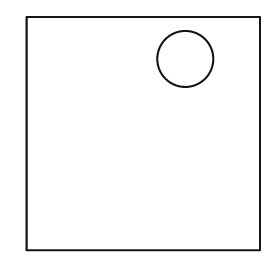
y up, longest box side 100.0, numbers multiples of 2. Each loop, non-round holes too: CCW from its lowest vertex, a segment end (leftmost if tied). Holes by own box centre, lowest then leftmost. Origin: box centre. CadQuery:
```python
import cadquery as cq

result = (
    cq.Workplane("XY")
    .moveTo(-50.0, -50.0)
    .lineTo(50.0, -50.0)
    .lineTo(50.0, 50.0)
    .lineTo(-50.0, 50.0)
    .close()
    .moveTo(18.0, 32.0)
    .circle(12.0)
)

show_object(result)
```